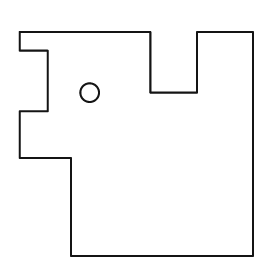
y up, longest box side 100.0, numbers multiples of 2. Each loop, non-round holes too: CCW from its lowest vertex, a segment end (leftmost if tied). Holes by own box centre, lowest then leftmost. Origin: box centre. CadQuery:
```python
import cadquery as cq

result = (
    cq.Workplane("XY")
    .moveTo(-28.0, -48.0)
    .lineTo(50.0, -48.0)
    .lineTo(50.0, 48.0)
    .lineTo(26.0, 48.0)
    .lineTo(26.0, 22.0)
    .lineTo(6.0, 22.0)
    .lineTo(6.0, 48.0)
    .lineTo(-50.0, 48.0)
    .lineTo(-50.0, 40.0)
    .lineTo(-38.0, 40.0)
    .lineTo(-38.0, 14.0)
    .lineTo(-50.0, 14.0)
    .lineTo(-50.0, -6.0)
    .lineTo(-28.0, -6.0)
    .close()
    .moveTo(-20.0, 22.0)
    .circle(4.0)
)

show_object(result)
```